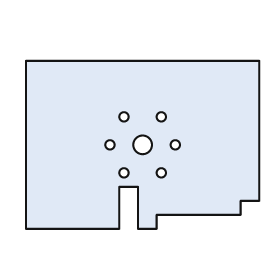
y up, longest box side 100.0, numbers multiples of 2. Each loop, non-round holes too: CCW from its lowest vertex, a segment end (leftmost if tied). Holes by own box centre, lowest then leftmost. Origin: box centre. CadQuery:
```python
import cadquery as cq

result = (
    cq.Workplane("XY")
    .moveTo(-50.0, -36.0)
    .lineTo(-10.0, -36.0)
    .lineTo(-10.0, -18.0)
    .lineTo(-2.0, -18.0)
    .lineTo(-2.0, -36.0)
    .lineTo(6.0, -36.0)
    .lineTo(6.0, -30.0)
    .lineTo(42.0, -30.0)
    .lineTo(42.0, -24.0)
    .lineTo(50.0, -24.0)
    .lineTo(50.0, 36.0)
    .lineTo(-50.0, 36.0)
    .close()
    .moveTo(-8.0, -12.0)
    .circle(2.0)
    .moveTo(8.0, -12.0)
    .circle(2.0)
    .moveTo(-14.0, 0.0)
    .circle(2.0)
    .moveTo(0.0, 0.0)
    .circle(4.0)
    .moveTo(14.0, 0.0)
    .circle(2.0)
    .moveTo(-8.0, 12.0)
    .circle(2.0)
    .moveTo(8.0, 12.0)
    .circle(2.0)
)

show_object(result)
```